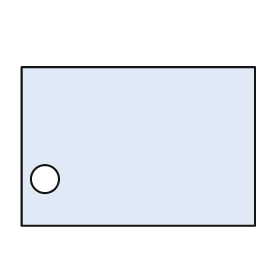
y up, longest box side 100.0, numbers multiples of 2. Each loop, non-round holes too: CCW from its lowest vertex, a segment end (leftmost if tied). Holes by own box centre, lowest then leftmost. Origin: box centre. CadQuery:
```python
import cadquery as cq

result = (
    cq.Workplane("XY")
    .moveTo(-50.0, -34.0)
    .lineTo(50.0, -34.0)
    .lineTo(50.0, 34.0)
    .lineTo(-50.0, 34.0)
    .close()
    .moveTo(-40.0, -14.0)
    .circle(6.0)
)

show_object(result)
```